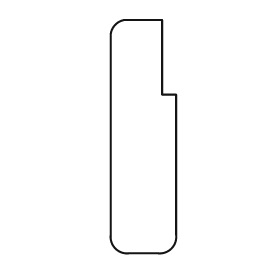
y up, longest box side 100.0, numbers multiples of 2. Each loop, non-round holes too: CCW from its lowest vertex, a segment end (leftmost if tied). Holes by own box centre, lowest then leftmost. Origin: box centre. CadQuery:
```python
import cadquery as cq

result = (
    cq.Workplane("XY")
    .moveTo(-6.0, -50.0)
    .lineTo(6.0, -50.0)
    .threePointArc((12.0, -48.0), (14.0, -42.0))
    .lineTo(14.0, 18.0)
    .lineTo(8.0, 18.0)
    .lineTo(8.0, 50.0)
    .lineTo(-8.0, 50.0)
    .threePointArc((-12.0, 48.0), (-14.0, 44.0))
    .lineTo(-14.0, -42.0)
    .threePointArc((-12.0, -48.0), (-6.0, -50.0))
    .close()
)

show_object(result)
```